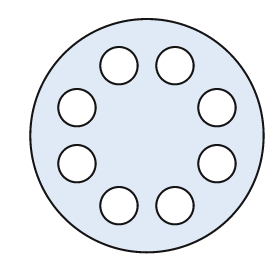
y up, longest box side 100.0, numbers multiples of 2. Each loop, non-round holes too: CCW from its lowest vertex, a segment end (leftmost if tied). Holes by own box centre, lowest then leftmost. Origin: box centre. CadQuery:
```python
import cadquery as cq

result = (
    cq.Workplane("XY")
    .moveTo(0.0, 0.0)
    .circle(50.0)
    .moveTo(-12.0, -30.0)
    .circle(8.0)
    .moveTo(12.0, -30.0)
    .circle(8.0)
    .moveTo(-30.0, -12.0)
    .circle(8.0)
    .moveTo(30.0, -12.0)
    .circle(8.0)
    .moveTo(-30.0, 12.0)
    .circle(8.0)
    .moveTo(30.0, 12.0)
    .circle(8.0)
    .moveTo(-12.0, 30.0)
    .circle(8.0)
    .moveTo(12.0, 30.0)
    .circle(8.0)
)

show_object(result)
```